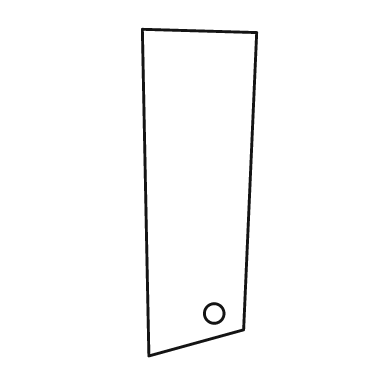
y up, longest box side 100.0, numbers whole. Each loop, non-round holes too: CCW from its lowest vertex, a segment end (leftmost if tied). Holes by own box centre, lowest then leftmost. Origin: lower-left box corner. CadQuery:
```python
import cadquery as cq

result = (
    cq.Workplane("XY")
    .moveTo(2.0, 0.0)
    .lineTo(31.0, 8.0)
    .lineTo(35.0, 99.0)
    .lineTo(0.0, 100.0)
    .close()
    .moveTo(22.0, 13.0)
    .circle(3.0)
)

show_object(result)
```